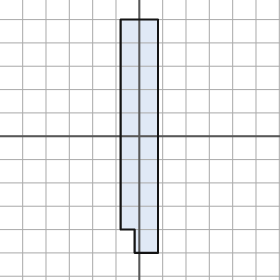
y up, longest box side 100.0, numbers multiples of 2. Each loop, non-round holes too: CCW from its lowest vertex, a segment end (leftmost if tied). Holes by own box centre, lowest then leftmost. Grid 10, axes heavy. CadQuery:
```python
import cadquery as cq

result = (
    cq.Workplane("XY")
    .moveTo(-2.0, -50.0)
    .lineTo(8.0, -50.0)
    .lineTo(8.0, 50.0)
    .lineTo(-8.0, 50.0)
    .lineTo(-8.0, -40.0)
    .lineTo(-2.0, -40.0)
    .close()
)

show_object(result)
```